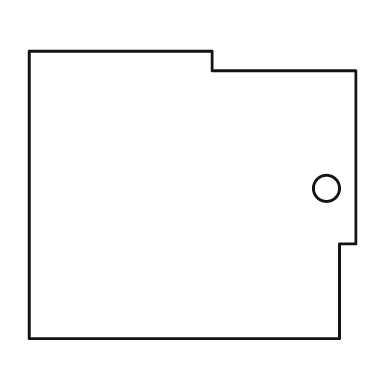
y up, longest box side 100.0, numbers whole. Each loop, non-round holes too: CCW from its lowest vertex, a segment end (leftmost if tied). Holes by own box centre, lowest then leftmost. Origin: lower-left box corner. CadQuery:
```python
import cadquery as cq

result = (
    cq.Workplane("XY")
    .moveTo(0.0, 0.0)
    .lineTo(95.0, 0.0)
    .lineTo(95.0, 29.0)
    .lineTo(100.0, 29.0)
    .lineTo(100.0, 82.0)
    .lineTo(56.0, 82.0)
    .lineTo(56.0, 88.0)
    .lineTo(0.0, 88.0)
    .close()
    .moveTo(91.0, 46.0)
    .circle(4.0)
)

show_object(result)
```